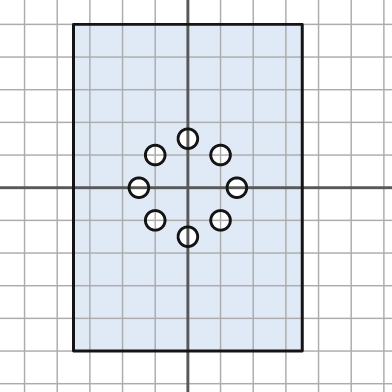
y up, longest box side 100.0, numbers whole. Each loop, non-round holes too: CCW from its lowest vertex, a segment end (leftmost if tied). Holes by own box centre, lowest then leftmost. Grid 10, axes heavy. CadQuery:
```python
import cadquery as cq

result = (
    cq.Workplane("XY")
    .moveTo(-35.0, -50.0)
    .lineTo(35.0, -50.0)
    .lineTo(35.0, 50.0)
    .lineTo(-35.0, 50.0)
    .close()
    .moveTo(0.0, -15.0)
    .circle(3.0)
    .moveTo(-10.0, -10.0)
    .circle(3.0)
    .moveTo(10.0, -10.0)
    .circle(3.0)
    .moveTo(-15.0, 0.0)
    .circle(3.0)
    .moveTo(15.0, 0.0)
    .circle(3.0)
    .moveTo(-10.0, 10.0)
    .circle(3.0)
    .moveTo(10.0, 10.0)
    .circle(3.0)
    .moveTo(0.0, 15.0)
    .circle(3.0)
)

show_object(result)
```